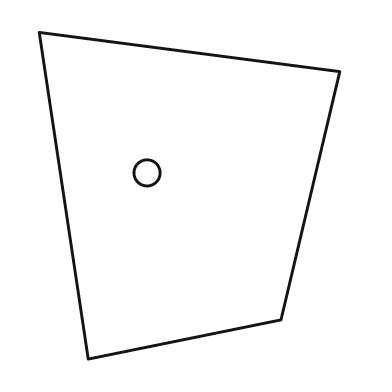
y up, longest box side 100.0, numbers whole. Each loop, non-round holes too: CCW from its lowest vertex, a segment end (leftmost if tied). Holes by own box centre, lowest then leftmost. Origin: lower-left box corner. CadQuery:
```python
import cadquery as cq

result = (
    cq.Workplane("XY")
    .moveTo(15.0, 0.0)
    .lineTo(74.0, 12.0)
    .lineTo(92.0, 88.0)
    .lineTo(0.0, 100.0)
    .close()
    .moveTo(33.0, 57.0)
    .circle(4.0)
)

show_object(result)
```